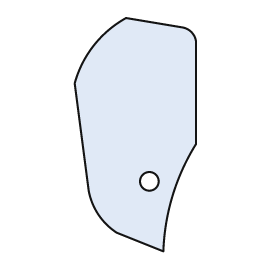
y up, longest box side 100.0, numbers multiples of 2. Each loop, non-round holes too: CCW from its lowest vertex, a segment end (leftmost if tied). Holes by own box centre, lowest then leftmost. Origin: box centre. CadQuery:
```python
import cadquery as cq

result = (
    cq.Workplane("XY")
    .moveTo(12.0, -50.0)
    .threePointArc((16.0, -26.0), (26.0, -4.0))
    .lineTo(26.0, 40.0)
    .threePointArc((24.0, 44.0), (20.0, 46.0))
    .lineTo(-4.0, 50.0)
    .threePointArc((-18.0, 38.0), (-26.0, 22.0))
    .lineTo(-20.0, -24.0)
    .threePointArc((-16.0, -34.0), (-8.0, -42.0))
    .close()
    .moveTo(6.0, -20.0)
    .circle(4.0)
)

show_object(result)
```